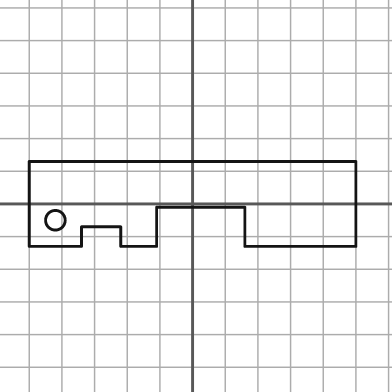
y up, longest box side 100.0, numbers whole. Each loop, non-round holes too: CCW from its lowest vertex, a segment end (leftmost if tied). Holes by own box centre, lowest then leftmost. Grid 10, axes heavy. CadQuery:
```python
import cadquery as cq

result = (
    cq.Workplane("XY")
    .moveTo(-50.0, -13.0)
    .lineTo(-34.0, -13.0)
    .lineTo(-34.0, -7.0)
    .lineTo(-22.0, -7.0)
    .lineTo(-22.0, -13.0)
    .lineTo(-11.0, -13.0)
    .lineTo(-11.0, -1.0)
    .lineTo(16.0, -1.0)
    .lineTo(16.0, -13.0)
    .lineTo(50.0, -13.0)
    .lineTo(50.0, 13.0)
    .lineTo(-50.0, 13.0)
    .close()
    .moveTo(-42.0, -5.0)
    .circle(3.0)
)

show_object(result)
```